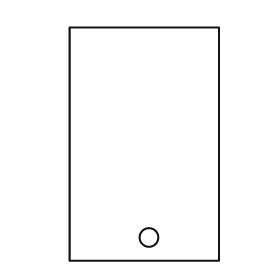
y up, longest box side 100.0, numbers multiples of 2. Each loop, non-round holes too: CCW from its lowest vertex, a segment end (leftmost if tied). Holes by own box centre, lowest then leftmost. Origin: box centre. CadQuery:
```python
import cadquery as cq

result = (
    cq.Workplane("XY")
    .moveTo(-32.0, -50.0)
    .lineTo(32.0, -50.0)
    .lineTo(32.0, 50.0)
    .lineTo(-32.0, 50.0)
    .close()
    .moveTo(2.0, -40.0)
    .circle(4.0)
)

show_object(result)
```